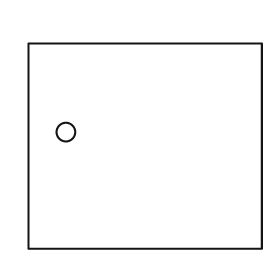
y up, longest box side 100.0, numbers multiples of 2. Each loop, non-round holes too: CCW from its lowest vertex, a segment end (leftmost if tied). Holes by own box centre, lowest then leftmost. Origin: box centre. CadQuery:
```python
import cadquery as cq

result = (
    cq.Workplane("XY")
    .moveTo(-50.0, -44.0)
    .lineTo(50.0, -44.0)
    .lineTo(50.0, 44.0)
    .lineTo(-50.0, 44.0)
    .close()
    .moveTo(-34.0, 6.0)
    .circle(4.0)
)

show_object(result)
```